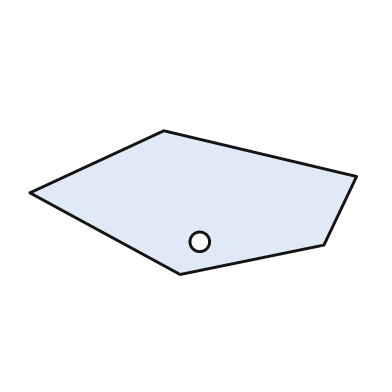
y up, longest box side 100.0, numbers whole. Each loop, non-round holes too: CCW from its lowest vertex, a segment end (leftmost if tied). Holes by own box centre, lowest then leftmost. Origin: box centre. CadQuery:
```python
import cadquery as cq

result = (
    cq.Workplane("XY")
    .moveTo(-4.0, -22.0)
    .lineTo(40.0, -13.0)
    .lineTo(50.0, 8.0)
    .lineTo(-9.0, 22.0)
    .lineTo(-50.0, 3.0)
    .close()
    .moveTo(2.0, -12.0)
    .circle(3.0)
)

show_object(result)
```